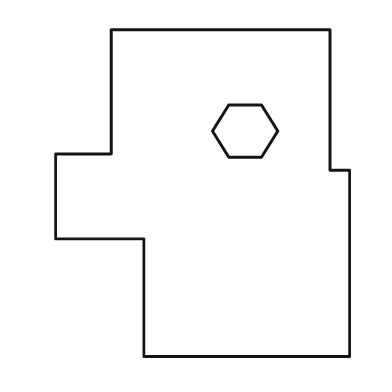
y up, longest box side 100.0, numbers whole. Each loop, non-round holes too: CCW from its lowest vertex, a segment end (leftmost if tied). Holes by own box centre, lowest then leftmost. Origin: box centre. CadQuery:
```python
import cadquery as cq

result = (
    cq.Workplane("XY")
    .moveTo(-18.0, -50.0)
    .lineTo(45.0, -50.0)
    .lineTo(45.0, 7.0)
    .lineTo(39.0, 7.0)
    .lineTo(39.0, 50.0)
    .lineTo(-28.0, 50.0)
    .lineTo(-28.0, 12.0)
    .lineTo(-45.0, 12.0)
    .lineTo(-45.0, -14.0)
    .lineTo(-18.0, -14.0)
    .close()
    .moveTo(8.0, 11.0)
    .lineTo(18.0, 11.0)
    .lineTo(23.0, 19.0)
    .lineTo(18.0, 27.0)
    .lineTo(8.0, 27.0)
    .lineTo(3.0, 19.0)
    .close()
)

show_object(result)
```